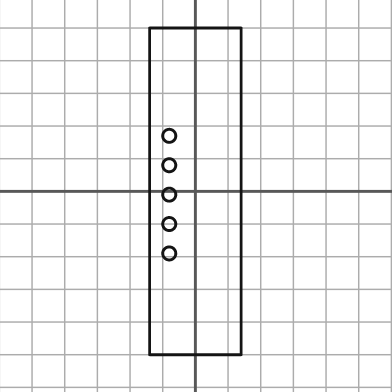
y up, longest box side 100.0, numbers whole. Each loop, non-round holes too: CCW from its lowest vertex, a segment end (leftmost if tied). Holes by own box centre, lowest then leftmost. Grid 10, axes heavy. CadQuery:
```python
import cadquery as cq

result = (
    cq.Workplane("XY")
    .moveTo(-14.0, -50.0)
    .lineTo(14.0, -50.0)
    .lineTo(14.0, 50.0)
    .lineTo(-14.0, 50.0)
    .close()
    .moveTo(-8.0, -19.0)
    .circle(2.0)
    .moveTo(-8.0, -10.0)
    .circle(2.0)
    .moveTo(-8.0, -1.0)
    .circle(2.0)
    .moveTo(-8.0, 8.0)
    .circle(2.0)
    .moveTo(-8.0, 17.0)
    .circle(2.0)
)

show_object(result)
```